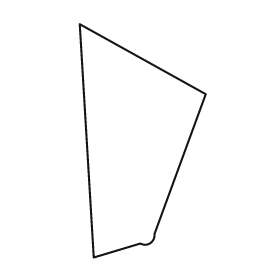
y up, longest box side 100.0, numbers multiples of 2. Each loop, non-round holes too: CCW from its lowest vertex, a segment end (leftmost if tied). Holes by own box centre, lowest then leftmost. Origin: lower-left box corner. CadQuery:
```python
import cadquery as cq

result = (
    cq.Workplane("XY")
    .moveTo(6.0, 0.0)
    .lineTo(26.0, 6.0)
    .threePointArc((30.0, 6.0), (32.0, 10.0))
    .lineTo(54.0, 70.0)
    .lineTo(0.0, 100.0)
    .close()
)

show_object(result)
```